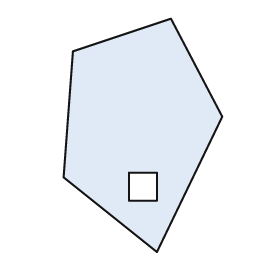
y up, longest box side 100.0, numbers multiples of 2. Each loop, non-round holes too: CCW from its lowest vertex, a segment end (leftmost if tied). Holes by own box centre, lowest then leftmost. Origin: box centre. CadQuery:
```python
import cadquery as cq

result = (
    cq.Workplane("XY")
    .moveTo(6.0, -50.0)
    .lineTo(34.0, 8.0)
    .lineTo(12.0, 50.0)
    .lineTo(-30.0, 36.0)
    .lineTo(-34.0, -18.0)
    .close()
    .moveTo(-6.0, -28.0)
    .lineTo(6.0, -28.0)
    .lineTo(6.0, -16.0)
    .lineTo(-6.0, -16.0)
    .close()
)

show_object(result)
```